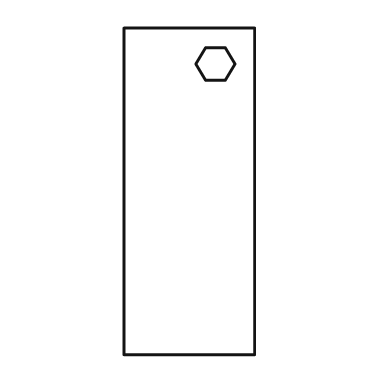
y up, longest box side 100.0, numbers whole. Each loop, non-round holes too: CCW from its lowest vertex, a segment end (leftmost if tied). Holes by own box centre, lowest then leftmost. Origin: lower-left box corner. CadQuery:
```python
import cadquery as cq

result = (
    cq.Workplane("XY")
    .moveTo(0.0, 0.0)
    .lineTo(40.0, 0.0)
    .lineTo(40.0, 100.0)
    .lineTo(0.0, 100.0)
    .close()
    .moveTo(25.0, 84.0)
    .lineTo(31.0, 84.0)
    .lineTo(34.0, 89.0)
    .lineTo(31.0, 94.0)
    .lineTo(25.0, 94.0)
    .lineTo(22.0, 89.0)
    .close()
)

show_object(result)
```